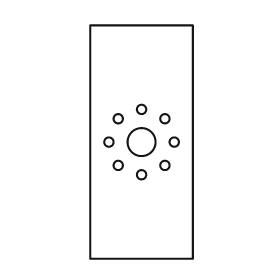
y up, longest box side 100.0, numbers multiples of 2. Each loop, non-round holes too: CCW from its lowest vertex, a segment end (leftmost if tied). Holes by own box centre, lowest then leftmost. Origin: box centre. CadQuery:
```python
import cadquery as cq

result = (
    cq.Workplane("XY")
    .moveTo(-22.0, -50.0)
    .lineTo(22.0, -50.0)
    .lineTo(22.0, 50.0)
    .lineTo(-22.0, 50.0)
    .close()
    .moveTo(0.0, -14.0)
    .circle(2.0)
    .moveTo(-10.0, -10.0)
    .circle(2.0)
    .moveTo(10.0, -10.0)
    .circle(2.0)
    .moveTo(-14.0, 0.0)
    .circle(2.0)
    .moveTo(0.0, 0.0)
    .circle(6.0)
    .moveTo(14.0, 0.0)
    .circle(2.0)
    .moveTo(-10.0, 10.0)
    .circle(2.0)
    .moveTo(10.0, 10.0)
    .circle(2.0)
    .moveTo(0.0, 14.0)
    .circle(2.0)
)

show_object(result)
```